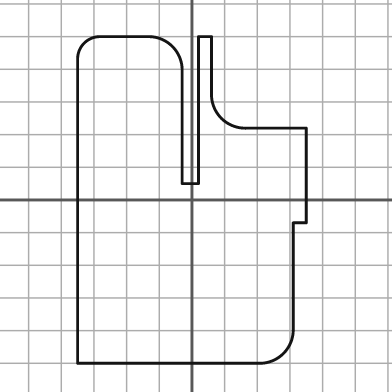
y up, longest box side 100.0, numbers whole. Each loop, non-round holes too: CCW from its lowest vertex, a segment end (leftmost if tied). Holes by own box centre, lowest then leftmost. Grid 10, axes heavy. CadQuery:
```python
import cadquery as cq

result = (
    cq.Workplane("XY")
    .moveTo(-35.0, -50.0)
    .lineTo(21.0, -50.0)
    .threePointArc((28.0, -47.0), (31.0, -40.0))
    .lineTo(31.0, -7.0)
    .lineTo(35.0, -7.0)
    .lineTo(35.0, 22.0)
    .lineTo(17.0, 22.0)
    .threePointArc((9.0, 25.0), (6.0, 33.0))
    .lineTo(6.0, 50.0)
    .lineTo(2.0, 50.0)
    .lineTo(2.0, 5.0)
    .lineTo(-3.0, 5.0)
    .lineTo(-3.0, 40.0)
    .threePointArc((-6.0, 47.0), (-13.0, 50.0))
    .lineTo(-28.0, 50.0)
    .threePointArc((-33.0, 48.0), (-35.0, 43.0))
    .close()
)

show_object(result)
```